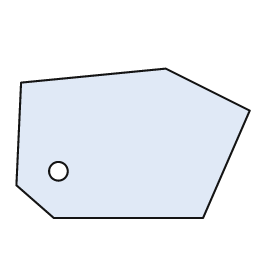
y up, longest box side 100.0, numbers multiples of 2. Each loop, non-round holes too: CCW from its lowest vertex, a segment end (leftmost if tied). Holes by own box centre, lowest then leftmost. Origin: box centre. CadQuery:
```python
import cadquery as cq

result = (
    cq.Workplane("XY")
    .moveTo(-34.0, -32.0)
    .lineTo(30.0, -32.0)
    .lineTo(50.0, 14.0)
    .lineTo(14.0, 32.0)
    .lineTo(-48.0, 26.0)
    .lineTo(-50.0, -18.0)
    .close()
    .moveTo(-32.0, -12.0)
    .circle(4.0)
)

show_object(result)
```